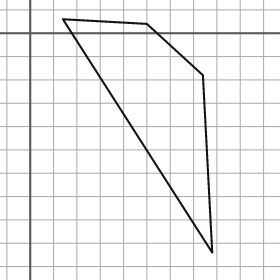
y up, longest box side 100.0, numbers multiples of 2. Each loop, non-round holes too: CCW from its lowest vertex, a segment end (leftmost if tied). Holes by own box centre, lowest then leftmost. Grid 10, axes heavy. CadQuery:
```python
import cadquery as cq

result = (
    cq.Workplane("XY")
    .moveTo(78.0, -94.0)
    .lineTo(74.0, -18.0)
    .lineTo(50.0, 4.0)
    .lineTo(14.0, 6.0)
    .close()
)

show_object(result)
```